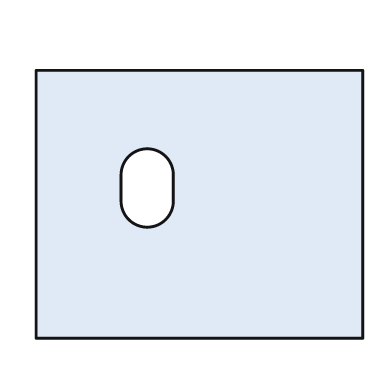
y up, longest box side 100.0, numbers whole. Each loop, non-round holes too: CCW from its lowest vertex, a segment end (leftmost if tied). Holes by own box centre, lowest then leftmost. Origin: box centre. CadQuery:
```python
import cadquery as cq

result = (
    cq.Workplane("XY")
    .moveTo(-50.0, -41.0)
    .lineTo(50.0, -41.0)
    .lineTo(50.0, 41.0)
    .lineTo(-50.0, 41.0)
    .close()
    .moveTo(-24.0, 1.0)
    .threePointArc((-16.0, -7.0), (-8.0, 1.0))
    .lineTo(-8.0, 9.0)
    .threePointArc((-16.0, 17.0), (-24.0, 9.0))
    .close()
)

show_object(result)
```